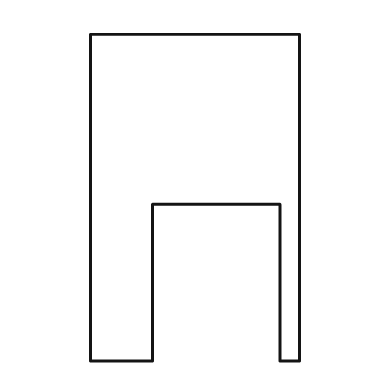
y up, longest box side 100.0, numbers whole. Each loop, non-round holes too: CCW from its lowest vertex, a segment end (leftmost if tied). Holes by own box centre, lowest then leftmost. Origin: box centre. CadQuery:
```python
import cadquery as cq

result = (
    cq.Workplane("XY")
    .moveTo(-32.0, -50.0)
    .lineTo(-13.0, -50.0)
    .lineTo(-13.0, -2.0)
    .lineTo(26.0, -2.0)
    .lineTo(26.0, -50.0)
    .lineTo(32.0, -50.0)
    .lineTo(32.0, 50.0)
    .lineTo(-32.0, 50.0)
    .close()
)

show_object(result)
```